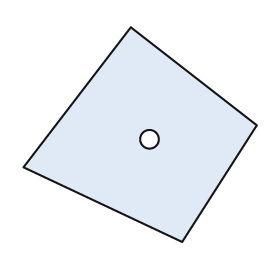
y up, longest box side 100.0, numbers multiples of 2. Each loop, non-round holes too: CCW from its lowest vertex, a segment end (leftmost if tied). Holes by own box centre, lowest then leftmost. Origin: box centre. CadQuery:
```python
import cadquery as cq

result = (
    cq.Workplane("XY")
    .moveTo(18.0, -46.0)
    .lineTo(50.0, 4.0)
    .lineTo(-4.0, 46.0)
    .lineTo(-50.0, -14.0)
    .close()
    .moveTo(4.0, -2.0)
    .circle(4.0)
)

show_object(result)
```